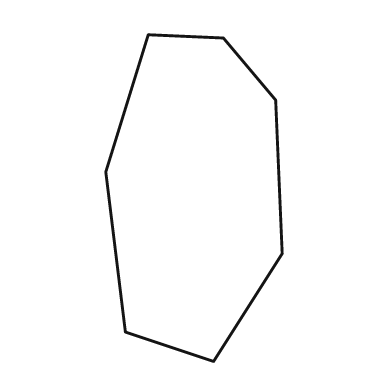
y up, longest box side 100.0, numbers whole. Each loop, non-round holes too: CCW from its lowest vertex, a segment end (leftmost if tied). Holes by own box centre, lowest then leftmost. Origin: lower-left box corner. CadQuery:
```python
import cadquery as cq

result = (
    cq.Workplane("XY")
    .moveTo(33.0, 0.0)
    .lineTo(54.0, 33.0)
    .lineTo(52.0, 80.0)
    .lineTo(36.0, 99.0)
    .lineTo(13.0, 100.0)
    .lineTo(0.0, 58.0)
    .lineTo(6.0, 9.0)
    .close()
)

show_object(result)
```